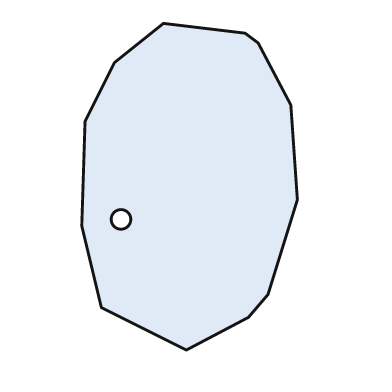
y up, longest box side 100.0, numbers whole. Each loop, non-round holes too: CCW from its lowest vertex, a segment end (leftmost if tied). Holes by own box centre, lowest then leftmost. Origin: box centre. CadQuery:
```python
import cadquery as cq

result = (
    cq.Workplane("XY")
    .moveTo(-1.0, -50.0)
    .lineTo(18.0, -40.0)
    .lineTo(24.0, -33.0)
    .lineTo(33.0, -4.0)
    .lineTo(31.0, 25.0)
    .lineTo(21.0, 44.0)
    .lineTo(17.0, 47.0)
    .lineTo(-8.0, 50.0)
    .lineTo(-23.0, 38.0)
    .lineTo(-32.0, 20.0)
    .lineTo(-33.0, -12.0)
    .lineTo(-27.0, -37.0)
    .close()
    .moveTo(-21.0, -10.0)
    .circle(3.0)
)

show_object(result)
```